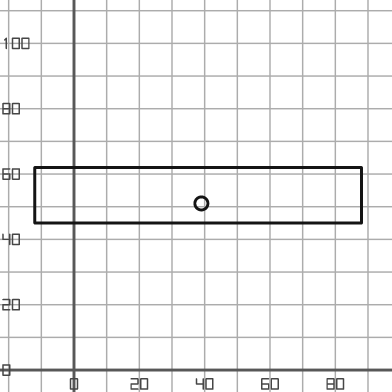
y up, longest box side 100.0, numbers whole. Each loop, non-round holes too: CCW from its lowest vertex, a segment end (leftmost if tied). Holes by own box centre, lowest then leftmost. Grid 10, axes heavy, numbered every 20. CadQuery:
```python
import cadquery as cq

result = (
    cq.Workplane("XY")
    .moveTo(-12.0, 45.0)
    .lineTo(88.0, 45.0)
    .lineTo(88.0, 62.0)
    .lineTo(-12.0, 62.0)
    .close()
    .moveTo(39.0, 51.0)
    .circle(2.0)
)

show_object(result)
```